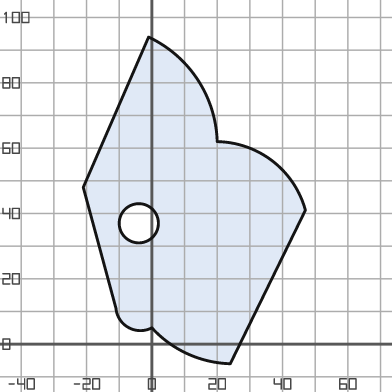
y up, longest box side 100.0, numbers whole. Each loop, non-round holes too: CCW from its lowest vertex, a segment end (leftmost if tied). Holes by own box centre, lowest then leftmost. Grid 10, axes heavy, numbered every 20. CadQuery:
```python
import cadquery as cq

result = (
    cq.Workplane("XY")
    .moveTo(24.0, -6.0)
    .lineTo(47.0, 41.0)
    .threePointArc((37.0, 56.0), (20.0, 62.0))
    .threePointArc((14.0, 81.0), (-1.0, 94.0))
    .lineTo(-21.0, 48.0)
    .lineTo(-11.0, 11.0)
    .threePointArc((-7.0, 5.0), (0.0, 5.0))
    .threePointArc((11.0, -3.0), (24.0, -6.0))
    .close()
    .moveTo(-4.0, 37.0)
    .circle(6.0)
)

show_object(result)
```